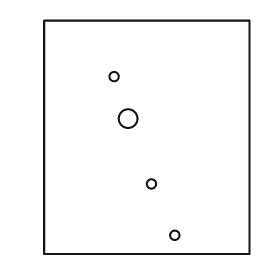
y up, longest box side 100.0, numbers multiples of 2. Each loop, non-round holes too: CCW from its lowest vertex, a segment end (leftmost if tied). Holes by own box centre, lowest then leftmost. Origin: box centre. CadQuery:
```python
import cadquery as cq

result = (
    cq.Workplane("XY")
    .moveTo(-44.0, -50.0)
    .lineTo(44.0, -50.0)
    .lineTo(44.0, 50.0)
    .lineTo(-44.0, 50.0)
    .close()
    .moveTo(12.0, -42.0)
    .circle(2.0)
    .moveTo(2.0, -20.0)
    .circle(2.0)
    .moveTo(-8.0, 8.0)
    .circle(4.0)
    .moveTo(-14.0, 26.0)
    .circle(2.0)
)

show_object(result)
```